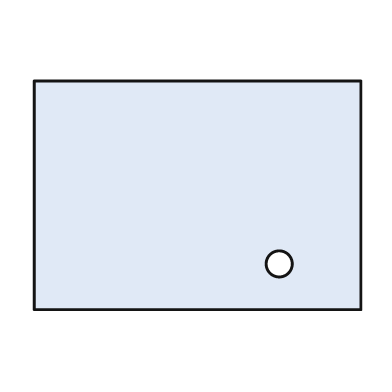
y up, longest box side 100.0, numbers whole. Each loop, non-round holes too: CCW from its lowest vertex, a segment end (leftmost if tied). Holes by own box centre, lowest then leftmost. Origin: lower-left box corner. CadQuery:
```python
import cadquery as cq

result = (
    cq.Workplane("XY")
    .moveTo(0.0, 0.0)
    .lineTo(100.0, 0.0)
    .lineTo(100.0, 70.0)
    .lineTo(0.0, 70.0)
    .close()
    .moveTo(75.0, 14.0)
    .circle(4.0)
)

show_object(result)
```